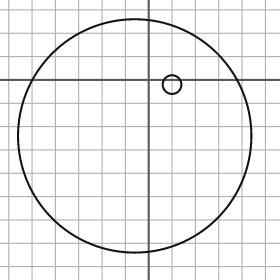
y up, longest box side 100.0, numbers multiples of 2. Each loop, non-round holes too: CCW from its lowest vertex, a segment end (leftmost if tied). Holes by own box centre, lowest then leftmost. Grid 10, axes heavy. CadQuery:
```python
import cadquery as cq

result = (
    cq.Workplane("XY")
    .moveTo(-6.0, -24.0)
    .circle(50.0)
    .moveTo(10.0, -2.0)
    .circle(4.0)
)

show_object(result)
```